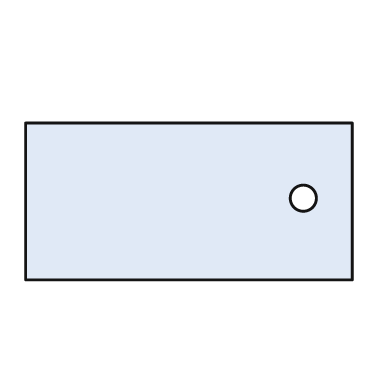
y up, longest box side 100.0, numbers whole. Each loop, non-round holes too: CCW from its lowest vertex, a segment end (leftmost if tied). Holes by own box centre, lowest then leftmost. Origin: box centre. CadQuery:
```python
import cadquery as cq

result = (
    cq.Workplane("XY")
    .moveTo(-50.0, -24.0)
    .lineTo(50.0, -24.0)
    .lineTo(50.0, 24.0)
    .lineTo(-50.0, 24.0)
    .close()
    .moveTo(35.0, 1.0)
    .circle(4.0)
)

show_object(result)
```